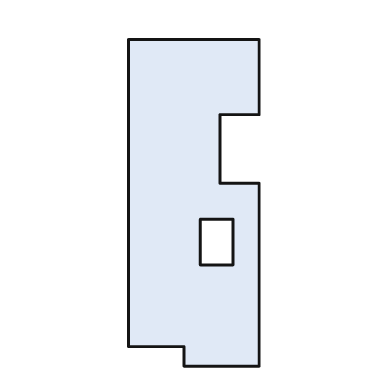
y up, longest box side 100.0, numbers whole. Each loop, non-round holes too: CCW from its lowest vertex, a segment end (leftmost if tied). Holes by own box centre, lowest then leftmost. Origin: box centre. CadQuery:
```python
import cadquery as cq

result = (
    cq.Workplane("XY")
    .moveTo(-3.0, -50.0)
    .lineTo(20.0, -50.0)
    .lineTo(20.0, 6.0)
    .lineTo(8.0, 6.0)
    .lineTo(8.0, 27.0)
    .lineTo(20.0, 27.0)
    .lineTo(20.0, 50.0)
    .lineTo(-20.0, 50.0)
    .lineTo(-20.0, -44.0)
    .lineTo(-3.0, -44.0)
    .close()
    .moveTo(2.0, -19.0)
    .lineTo(12.0, -19.0)
    .lineTo(12.0, -5.0)
    .lineTo(2.0, -5.0)
    .close()
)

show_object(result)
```